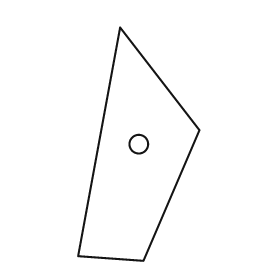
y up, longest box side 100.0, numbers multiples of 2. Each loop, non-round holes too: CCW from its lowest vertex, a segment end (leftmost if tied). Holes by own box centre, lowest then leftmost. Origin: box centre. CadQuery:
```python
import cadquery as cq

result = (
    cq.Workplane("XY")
    .moveTo(2.0, -50.0)
    .lineTo(26.0, 6.0)
    .lineTo(-8.0, 50.0)
    .lineTo(-26.0, -48.0)
    .close()
    .moveTo(0.0, 0.0)
    .circle(4.0)
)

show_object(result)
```